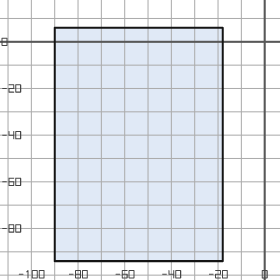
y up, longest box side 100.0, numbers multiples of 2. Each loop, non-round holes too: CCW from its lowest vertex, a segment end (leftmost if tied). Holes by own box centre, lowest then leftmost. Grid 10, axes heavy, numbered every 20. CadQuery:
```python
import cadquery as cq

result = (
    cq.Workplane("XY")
    .moveTo(-90.0, -94.0)
    .lineTo(-18.0, -94.0)
    .lineTo(-18.0, 6.0)
    .lineTo(-90.0, 6.0)
    .close()
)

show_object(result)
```